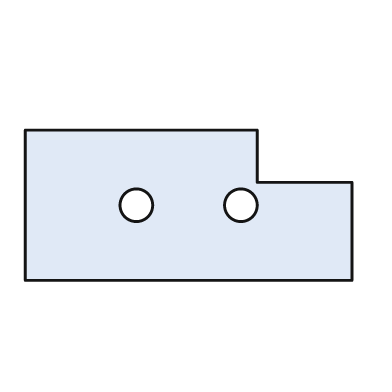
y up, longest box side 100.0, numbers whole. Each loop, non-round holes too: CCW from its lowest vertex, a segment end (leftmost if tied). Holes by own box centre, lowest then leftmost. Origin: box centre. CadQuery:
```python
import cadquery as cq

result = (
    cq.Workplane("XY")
    .moveTo(-50.0, -23.0)
    .lineTo(50.0, -23.0)
    .lineTo(50.0, 7.0)
    .lineTo(21.0, 7.0)
    .lineTo(21.0, 23.0)
    .lineTo(-50.0, 23.0)
    .close()
    .moveTo(-16.0, 0.0)
    .circle(5.0)
    .moveTo(16.0, 0.0)
    .circle(5.0)
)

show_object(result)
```